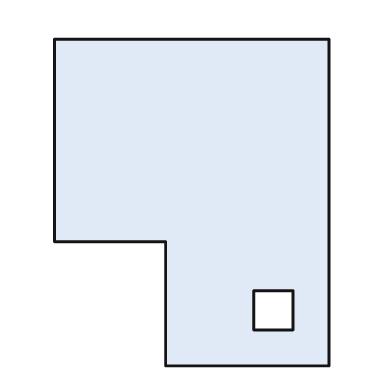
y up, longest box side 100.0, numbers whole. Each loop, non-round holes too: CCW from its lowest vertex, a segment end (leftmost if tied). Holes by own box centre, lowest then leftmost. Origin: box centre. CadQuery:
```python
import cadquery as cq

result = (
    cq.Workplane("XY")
    .moveTo(-8.0, -50.0)
    .lineTo(42.0, -50.0)
    .lineTo(42.0, 50.0)
    .lineTo(-42.0, 50.0)
    .lineTo(-42.0, -12.0)
    .lineTo(-8.0, -12.0)
    .close()
    .moveTo(19.0, -39.0)
    .lineTo(31.0, -39.0)
    .lineTo(31.0, -27.0)
    .lineTo(19.0, -27.0)
    .close()
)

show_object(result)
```